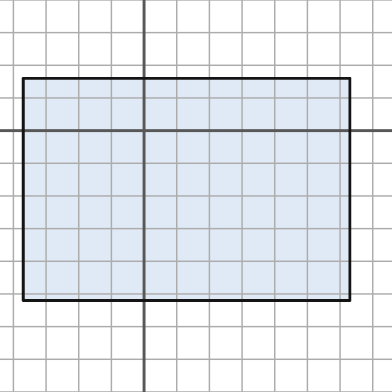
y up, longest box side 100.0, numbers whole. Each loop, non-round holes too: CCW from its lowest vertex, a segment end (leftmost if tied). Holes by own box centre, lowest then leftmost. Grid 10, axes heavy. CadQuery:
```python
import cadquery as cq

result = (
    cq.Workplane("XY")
    .moveTo(-37.0, -52.0)
    .lineTo(63.0, -52.0)
    .lineTo(63.0, 16.0)
    .lineTo(-37.0, 16.0)
    .close()
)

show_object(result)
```